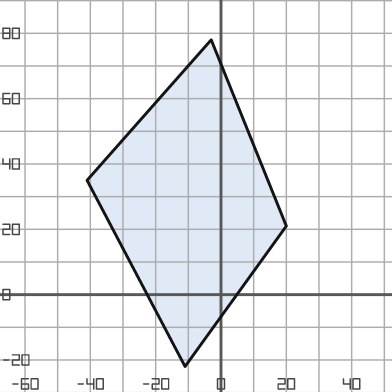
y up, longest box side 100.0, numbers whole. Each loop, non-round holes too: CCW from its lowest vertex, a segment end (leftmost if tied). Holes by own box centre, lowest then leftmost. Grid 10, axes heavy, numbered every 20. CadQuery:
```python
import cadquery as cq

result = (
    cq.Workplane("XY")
    .moveTo(-11.0, -22.0)
    .lineTo(20.0, 21.0)
    .lineTo(-3.0, 78.0)
    .lineTo(-41.0, 35.0)
    .close()
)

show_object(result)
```